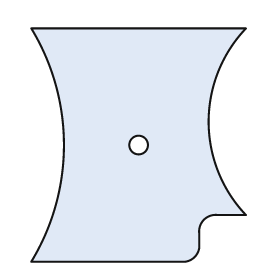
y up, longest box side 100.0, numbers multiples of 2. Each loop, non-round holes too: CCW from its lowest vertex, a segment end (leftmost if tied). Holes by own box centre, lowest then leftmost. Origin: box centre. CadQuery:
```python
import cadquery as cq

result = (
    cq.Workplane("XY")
    .moveTo(-46.0, -50.0)
    .lineTo(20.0, -50.0)
    .threePointArc((24.0, -48.0), (26.0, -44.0))
    .lineTo(26.0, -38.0)
    .threePointArc((28.0, -32.0), (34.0, -30.0))
    .lineTo(46.0, -30.0)
    .threePointArc((30.0, 10.0), (46.0, 50.0))
    .lineTo(-46.0, 50.0)
    .threePointArc((-32.0, 0.0), (-46.0, -50.0))
    .close()
    .moveTo(0.0, 0.0)
    .circle(4.0)
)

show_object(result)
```